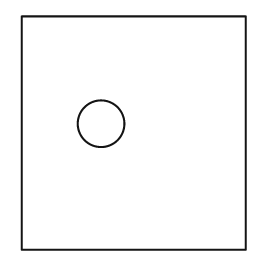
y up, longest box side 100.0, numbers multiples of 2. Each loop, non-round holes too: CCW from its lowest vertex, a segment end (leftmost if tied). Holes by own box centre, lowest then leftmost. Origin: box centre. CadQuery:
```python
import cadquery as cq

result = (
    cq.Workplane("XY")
    .moveTo(-48.0, -50.0)
    .lineTo(48.0, -50.0)
    .lineTo(48.0, 50.0)
    .lineTo(-48.0, 50.0)
    .close()
    .moveTo(-14.0, 4.0)
    .circle(10.0)
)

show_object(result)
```